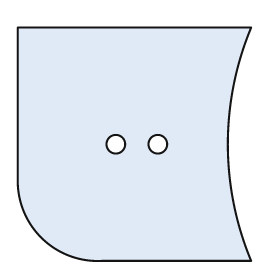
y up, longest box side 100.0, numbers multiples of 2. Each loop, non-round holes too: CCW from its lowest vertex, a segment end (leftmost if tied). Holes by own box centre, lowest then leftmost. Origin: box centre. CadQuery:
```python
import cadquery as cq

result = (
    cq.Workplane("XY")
    .moveTo(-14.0, -50.0)
    .lineTo(50.0, -50.0)
    .threePointArc((40.0, 0.0), (50.0, 50.0))
    .lineTo(-50.0, 50.0)
    .lineTo(-50.0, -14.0)
    .threePointArc((-40.0, -40.0), (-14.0, -50.0))
    .close()
    .moveTo(-8.0, 0.0)
    .circle(4.0)
    .moveTo(10.0, 0.0)
    .circle(4.0)
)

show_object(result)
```